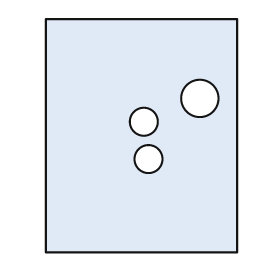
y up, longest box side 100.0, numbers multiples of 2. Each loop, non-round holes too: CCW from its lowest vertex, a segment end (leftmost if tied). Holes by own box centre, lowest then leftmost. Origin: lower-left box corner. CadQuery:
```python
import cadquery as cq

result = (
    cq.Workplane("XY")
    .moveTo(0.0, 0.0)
    .lineTo(82.0, 0.0)
    .lineTo(82.0, 100.0)
    .lineTo(0.0, 100.0)
    .close()
    .moveTo(44.0, 40.0)
    .circle(6.0)
    .moveTo(42.0, 56.0)
    .circle(6.0)
    .moveTo(66.0, 66.0)
    .circle(8.0)
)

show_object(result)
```